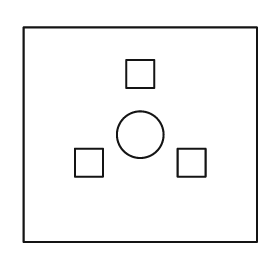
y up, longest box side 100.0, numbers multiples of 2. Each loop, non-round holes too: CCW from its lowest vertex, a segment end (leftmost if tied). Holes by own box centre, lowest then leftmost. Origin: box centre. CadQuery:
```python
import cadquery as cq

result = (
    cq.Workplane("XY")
    .moveTo(-50.0, -46.0)
    .lineTo(50.0, -46.0)
    .lineTo(50.0, 46.0)
    .lineTo(-50.0, 46.0)
    .close()
    .moveTo(-28.0, -18.0)
    .lineTo(-16.0, -18.0)
    .lineTo(-16.0, -6.0)
    .lineTo(-28.0, -6.0)
    .close()
    .moveTo(16.0, -18.0)
    .lineTo(28.0, -18.0)
    .lineTo(28.0, -6.0)
    .lineTo(16.0, -6.0)
    .close()
    .moveTo(0.0, 0.0)
    .circle(10.0)
    .moveTo(-6.0, 20.0)
    .lineTo(6.0, 20.0)
    .lineTo(6.0, 32.0)
    .lineTo(-6.0, 32.0)
    .close()
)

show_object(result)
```